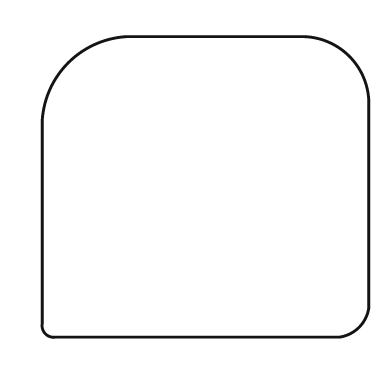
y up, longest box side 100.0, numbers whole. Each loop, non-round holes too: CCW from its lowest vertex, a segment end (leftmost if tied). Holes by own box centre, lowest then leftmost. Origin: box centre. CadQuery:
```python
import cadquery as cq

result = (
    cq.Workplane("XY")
    .moveTo(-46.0, -46.0)
    .lineTo(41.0, -46.0)
    .threePointArc((47.0, -43.0), (50.0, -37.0))
    .lineTo(50.0, 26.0)
    .threePointArc((44.0, 40.0), (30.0, 46.0))
    .lineTo(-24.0, 46.0)
    .threePointArc((-42.0, 38.0), (-50.0, 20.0))
    .lineTo(-50.0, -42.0)
    .threePointArc((-49.0, -45.0), (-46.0, -46.0))
    .close()
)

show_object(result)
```